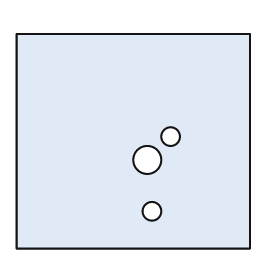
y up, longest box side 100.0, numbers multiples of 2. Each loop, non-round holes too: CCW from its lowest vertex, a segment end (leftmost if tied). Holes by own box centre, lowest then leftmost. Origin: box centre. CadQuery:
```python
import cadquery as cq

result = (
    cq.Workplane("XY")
    .moveTo(-50.0, -46.0)
    .lineTo(50.0, -46.0)
    .lineTo(50.0, 46.0)
    .lineTo(-50.0, 46.0)
    .close()
    .moveTo(8.0, -30.0)
    .circle(4.0)
    .moveTo(6.0, -8.0)
    .circle(6.0)
    .moveTo(16.0, 2.0)
    .circle(4.0)
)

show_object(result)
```